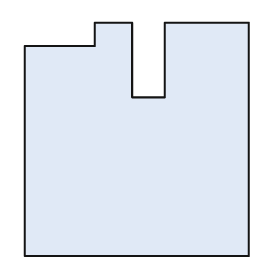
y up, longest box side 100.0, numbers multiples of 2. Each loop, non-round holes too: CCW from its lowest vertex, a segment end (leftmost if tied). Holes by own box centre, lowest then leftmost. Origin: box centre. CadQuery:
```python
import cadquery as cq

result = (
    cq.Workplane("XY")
    .moveTo(-48.0, -50.0)
    .lineTo(48.0, -50.0)
    .lineTo(48.0, 50.0)
    .lineTo(12.0, 50.0)
    .lineTo(12.0, 18.0)
    .lineTo(-2.0, 18.0)
    .lineTo(-2.0, 50.0)
    .lineTo(-18.0, 50.0)
    .lineTo(-18.0, 40.0)
    .lineTo(-48.0, 40.0)
    .close()
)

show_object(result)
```